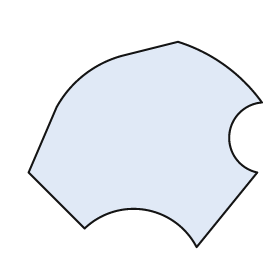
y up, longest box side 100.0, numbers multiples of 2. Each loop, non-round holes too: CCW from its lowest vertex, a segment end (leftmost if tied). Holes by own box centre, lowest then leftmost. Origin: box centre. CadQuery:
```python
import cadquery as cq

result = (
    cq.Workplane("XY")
    .moveTo(22.0, -44.0)
    .lineTo(48.0, -12.0)
    .threePointArc((36.0, 4.0), (50.0, 18.0))
    .threePointArc((34.0, 34.0), (14.0, 44.0))
    .lineTo(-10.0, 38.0)
    .threePointArc((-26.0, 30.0), (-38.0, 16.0))
    .lineTo(-50.0, -12.0)
    .lineTo(-26.0, -36.0)
    .threePointArc((0.0, -28.0), (22.0, -44.0))
    .close()
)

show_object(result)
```